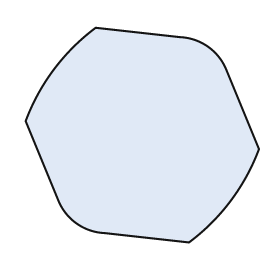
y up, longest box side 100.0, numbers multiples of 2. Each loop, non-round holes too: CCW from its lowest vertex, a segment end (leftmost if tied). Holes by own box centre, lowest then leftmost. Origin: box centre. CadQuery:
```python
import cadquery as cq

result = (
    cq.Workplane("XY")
    .moveTo(20.0, -46.0)
    .threePointArc((38.0, -28.0), (50.0, -6.0))
    .lineTo(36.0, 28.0)
    .threePointArc((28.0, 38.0), (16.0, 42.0))
    .lineTo(-20.0, 46.0)
    .threePointArc((-38.0, 28.0), (-50.0, 6.0))
    .lineTo(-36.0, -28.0)
    .threePointArc((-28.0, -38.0), (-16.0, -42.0))
    .close()
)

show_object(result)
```